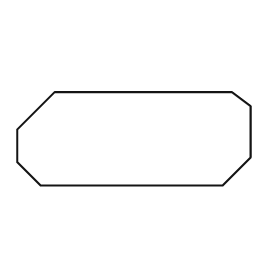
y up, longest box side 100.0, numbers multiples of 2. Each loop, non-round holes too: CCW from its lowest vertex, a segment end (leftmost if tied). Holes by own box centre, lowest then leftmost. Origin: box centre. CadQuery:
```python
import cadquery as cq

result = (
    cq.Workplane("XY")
    .moveTo(-40.0, -20.0)
    .lineTo(38.0, -20.0)
    .lineTo(50.0, -8.0)
    .lineTo(50.0, 14.0)
    .lineTo(42.0, 20.0)
    .lineTo(-34.0, 20.0)
    .lineTo(-50.0, 4.0)
    .lineTo(-50.0, -10.0)
    .close()
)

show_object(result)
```